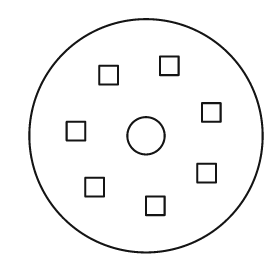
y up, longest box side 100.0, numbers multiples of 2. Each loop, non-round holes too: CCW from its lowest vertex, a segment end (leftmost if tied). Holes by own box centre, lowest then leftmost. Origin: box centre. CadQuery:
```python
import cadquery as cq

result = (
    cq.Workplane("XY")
    .moveTo(0.0, 0.0)
    .circle(50.0)
    .moveTo(0.0, -34.0)
    .lineTo(8.0, -34.0)
    .lineTo(8.0, -26.0)
    .lineTo(0.0, -26.0)
    .close()
    .moveTo(-26.0, -26.0)
    .lineTo(-18.0, -26.0)
    .lineTo(-18.0, -18.0)
    .lineTo(-26.0, -18.0)
    .close()
    .moveTo(22.0, -20.0)
    .lineTo(30.0, -20.0)
    .lineTo(30.0, -12.0)
    .lineTo(22.0, -12.0)
    .close()
    .moveTo(0.0, 0.0)
    .circle(8.0)
    .moveTo(-34.0, -2.0)
    .lineTo(-26.0, -2.0)
    .lineTo(-26.0, 6.0)
    .lineTo(-34.0, 6.0)
    .close()
    .moveTo(24.0, 6.0)
    .lineTo(32.0, 6.0)
    .lineTo(32.0, 14.0)
    .lineTo(24.0, 14.0)
    .close()
    .moveTo(-20.0, 22.0)
    .lineTo(-12.0, 22.0)
    .lineTo(-12.0, 30.0)
    .lineTo(-20.0, 30.0)
    .close()
    .moveTo(6.0, 26.0)
    .lineTo(14.0, 26.0)
    .lineTo(14.0, 34.0)
    .lineTo(6.0, 34.0)
    .close()
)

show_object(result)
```